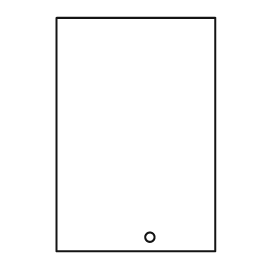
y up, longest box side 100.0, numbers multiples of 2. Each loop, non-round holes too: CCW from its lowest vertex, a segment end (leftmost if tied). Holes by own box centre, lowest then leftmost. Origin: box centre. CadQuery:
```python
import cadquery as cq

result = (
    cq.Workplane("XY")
    .moveTo(-34.0, -50.0)
    .lineTo(34.0, -50.0)
    .lineTo(34.0, 50.0)
    .lineTo(-34.0, 50.0)
    .close()
    .moveTo(6.0, -44.0)
    .circle(2.0)
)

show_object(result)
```